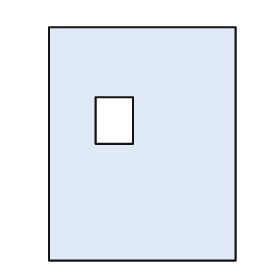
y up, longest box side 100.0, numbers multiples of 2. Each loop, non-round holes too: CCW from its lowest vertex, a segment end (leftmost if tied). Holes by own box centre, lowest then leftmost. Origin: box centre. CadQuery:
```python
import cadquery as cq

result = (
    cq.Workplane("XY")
    .moveTo(-40.0, -50.0)
    .lineTo(40.0, -50.0)
    .lineTo(40.0, 50.0)
    .lineTo(-40.0, 50.0)
    .close()
    .moveTo(-20.0, 0.0)
    .lineTo(-4.0, 0.0)
    .lineTo(-4.0, 20.0)
    .lineTo(-20.0, 20.0)
    .close()
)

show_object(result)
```